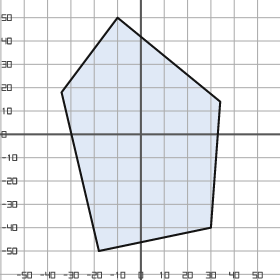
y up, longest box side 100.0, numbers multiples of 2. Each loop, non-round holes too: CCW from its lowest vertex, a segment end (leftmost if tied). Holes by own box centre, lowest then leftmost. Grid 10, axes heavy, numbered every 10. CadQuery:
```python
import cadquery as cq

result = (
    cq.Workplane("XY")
    .moveTo(-18.0, -50.0)
    .lineTo(30.0, -40.0)
    .lineTo(34.0, 14.0)
    .lineTo(-10.0, 50.0)
    .lineTo(-34.0, 18.0)
    .close()
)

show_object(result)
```